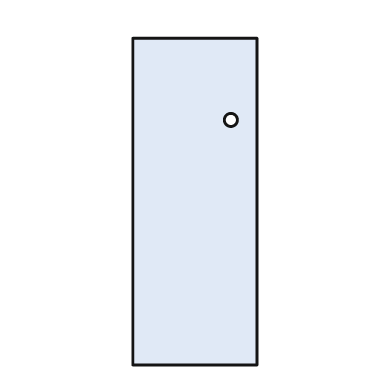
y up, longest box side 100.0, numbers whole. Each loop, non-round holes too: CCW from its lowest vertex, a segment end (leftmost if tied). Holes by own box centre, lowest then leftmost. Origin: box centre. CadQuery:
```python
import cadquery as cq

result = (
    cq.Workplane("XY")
    .moveTo(-19.0, -50.0)
    .lineTo(19.0, -50.0)
    .lineTo(19.0, 50.0)
    .lineTo(-19.0, 50.0)
    .close()
    .moveTo(11.0, 25.0)
    .circle(2.0)
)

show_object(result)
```